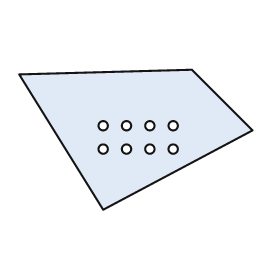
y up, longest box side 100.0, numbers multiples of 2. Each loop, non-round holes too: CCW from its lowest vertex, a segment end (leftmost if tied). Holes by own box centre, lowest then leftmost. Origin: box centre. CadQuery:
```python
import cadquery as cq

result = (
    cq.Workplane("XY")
    .moveTo(-14.0, -30.0)
    .lineTo(50.0, 4.0)
    .lineTo(24.0, 30.0)
    .lineTo(-50.0, 28.0)
    .close()
    .moveTo(-14.0, -4.0)
    .circle(2.0)
    .moveTo(-4.0, -4.0)
    .circle(2.0)
    .moveTo(6.0, -4.0)
    .circle(2.0)
    .moveTo(16.0, -4.0)
    .circle(2.0)
    .moveTo(-14.0, 6.0)
    .circle(2.0)
    .moveTo(-4.0, 6.0)
    .circle(2.0)
    .moveTo(6.0, 6.0)
    .circle(2.0)
    .moveTo(16.0, 6.0)
    .circle(2.0)
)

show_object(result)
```